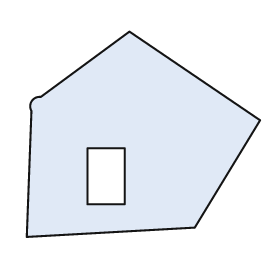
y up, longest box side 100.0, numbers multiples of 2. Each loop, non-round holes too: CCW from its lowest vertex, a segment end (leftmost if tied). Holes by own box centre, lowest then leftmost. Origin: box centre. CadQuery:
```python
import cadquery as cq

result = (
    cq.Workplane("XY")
    .moveTo(-50.0, -44.0)
    .lineTo(22.0, -40.0)
    .lineTo(50.0, 6.0)
    .lineTo(-6.0, 44.0)
    .lineTo(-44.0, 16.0)
    .threePointArc((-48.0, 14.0), (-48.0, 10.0))
    .close()
    .moveTo(-24.0, -30.0)
    .lineTo(-8.0, -30.0)
    .lineTo(-8.0, -6.0)
    .lineTo(-24.0, -6.0)
    .close()
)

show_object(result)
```